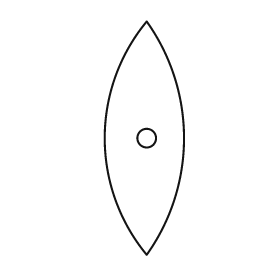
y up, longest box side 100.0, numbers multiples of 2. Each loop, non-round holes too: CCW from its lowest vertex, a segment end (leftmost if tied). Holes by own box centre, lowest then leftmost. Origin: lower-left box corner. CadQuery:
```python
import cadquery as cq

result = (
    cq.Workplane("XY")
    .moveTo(18.0, 0.0)
    .threePointArc((34.0, 50.0), (18.0, 100.0))
    .threePointArc((0.0, 50.0), (18.0, 0.0))
    .close()
    .moveTo(18.0, 50.0)
    .circle(4.0)
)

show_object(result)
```